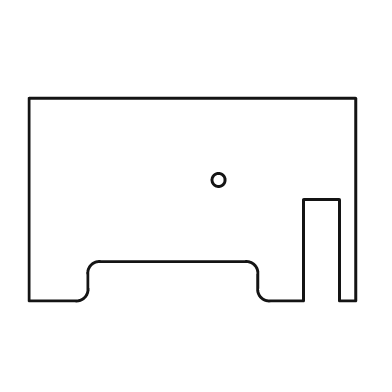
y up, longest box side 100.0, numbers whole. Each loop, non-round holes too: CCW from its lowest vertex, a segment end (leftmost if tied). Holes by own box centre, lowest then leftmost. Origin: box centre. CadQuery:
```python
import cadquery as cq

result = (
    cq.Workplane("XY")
    .moveTo(-50.0, -31.0)
    .lineTo(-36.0, -31.0)
    .threePointArc((-33.0, -30.0), (-32.0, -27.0))
    .lineTo(-32.0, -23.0)
    .threePointArc((-31.0, -20.0), (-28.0, -19.0))
    .lineTo(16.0, -19.0)
    .threePointArc((19.0, -20.0), (20.0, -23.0))
    .lineTo(20.0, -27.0)
    .threePointArc((21.0, -30.0), (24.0, -31.0))
    .lineTo(34.0, -31.0)
    .lineTo(34.0, 0.0)
    .lineTo(45.0, 0.0)
    .lineTo(45.0, -31.0)
    .lineTo(50.0, -31.0)
    .lineTo(50.0, 31.0)
    .lineTo(-50.0, 31.0)
    .close()
    .moveTo(8.0, 6.0)
    .circle(2.0)
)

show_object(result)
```